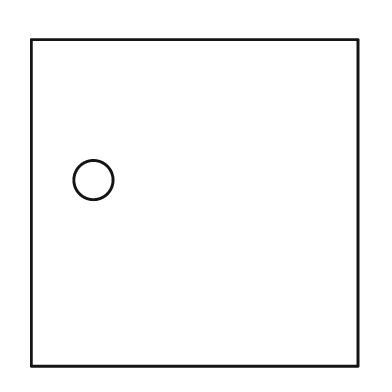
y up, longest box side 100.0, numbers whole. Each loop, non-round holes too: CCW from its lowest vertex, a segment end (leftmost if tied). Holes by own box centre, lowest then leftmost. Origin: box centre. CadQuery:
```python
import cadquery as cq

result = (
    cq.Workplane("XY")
    .moveTo(-50.0, -50.0)
    .lineTo(50.0, -50.0)
    .lineTo(50.0, 50.0)
    .lineTo(-50.0, 50.0)
    .close()
    .moveTo(-31.0, 7.0)
    .circle(6.0)
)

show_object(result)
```